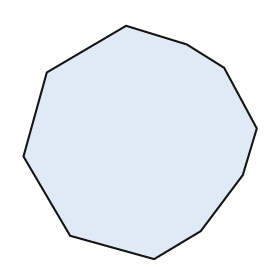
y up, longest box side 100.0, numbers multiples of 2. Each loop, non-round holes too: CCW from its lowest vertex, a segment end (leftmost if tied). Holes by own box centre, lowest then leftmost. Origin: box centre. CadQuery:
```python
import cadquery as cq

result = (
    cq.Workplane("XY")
    .moveTo(6.0, -50.0)
    .lineTo(26.0, -38.0)
    .lineTo(44.0, -14.0)
    .lineTo(50.0, 6.0)
    .lineTo(36.0, 32.0)
    .lineTo(20.0, 42.0)
    .lineTo(-6.0, 50.0)
    .lineTo(-40.0, 30.0)
    .lineTo(-50.0, -6.0)
    .lineTo(-30.0, -40.0)
    .close()
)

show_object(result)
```